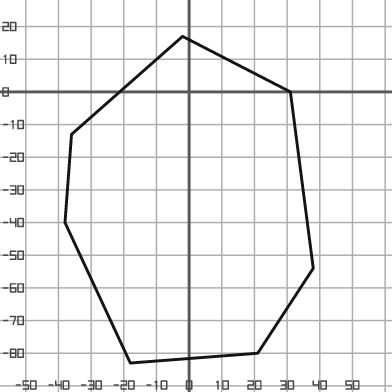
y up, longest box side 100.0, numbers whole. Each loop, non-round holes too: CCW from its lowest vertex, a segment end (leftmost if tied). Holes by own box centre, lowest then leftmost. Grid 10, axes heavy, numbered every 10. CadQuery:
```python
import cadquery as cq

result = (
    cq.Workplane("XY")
    .moveTo(-18.0, -83.0)
    .lineTo(21.0, -80.0)
    .lineTo(38.0, -54.0)
    .lineTo(31.0, 0.0)
    .lineTo(-2.0, 17.0)
    .lineTo(-36.0, -13.0)
    .lineTo(-38.0, -40.0)
    .close()
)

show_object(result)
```